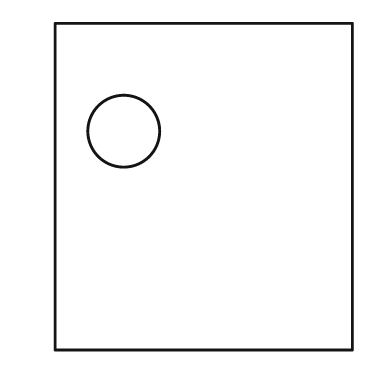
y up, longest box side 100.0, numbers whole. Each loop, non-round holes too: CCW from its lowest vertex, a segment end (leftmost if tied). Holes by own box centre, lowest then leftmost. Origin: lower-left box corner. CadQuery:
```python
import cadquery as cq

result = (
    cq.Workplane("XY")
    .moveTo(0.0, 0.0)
    .lineTo(91.0, 0.0)
    .lineTo(91.0, 100.0)
    .lineTo(0.0, 100.0)
    .close()
    .moveTo(21.0, 67.0)
    .circle(11.0)
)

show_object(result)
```